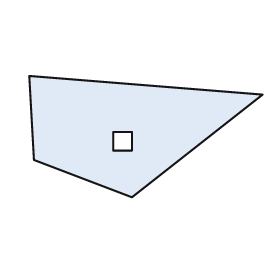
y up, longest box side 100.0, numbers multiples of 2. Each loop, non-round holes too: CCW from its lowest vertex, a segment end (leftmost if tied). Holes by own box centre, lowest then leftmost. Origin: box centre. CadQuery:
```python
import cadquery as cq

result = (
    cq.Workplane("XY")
    .moveTo(-6.0, -26.0)
    .lineTo(50.0, 18.0)
    .lineTo(-50.0, 26.0)
    .lineTo(-48.0, -10.0)
    .close()
    .moveTo(-14.0, -6.0)
    .lineTo(-6.0, -6.0)
    .lineTo(-6.0, 2.0)
    .lineTo(-14.0, 2.0)
    .close()
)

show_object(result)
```